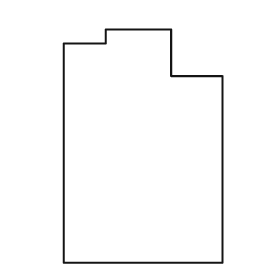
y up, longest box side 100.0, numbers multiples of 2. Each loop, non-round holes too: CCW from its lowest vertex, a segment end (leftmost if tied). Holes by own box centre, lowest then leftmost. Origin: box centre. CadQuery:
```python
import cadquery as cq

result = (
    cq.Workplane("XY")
    .moveTo(-34.0, -50.0)
    .lineTo(34.0, -50.0)
    .lineTo(34.0, 30.0)
    .lineTo(12.0, 30.0)
    .lineTo(12.0, 50.0)
    .lineTo(-16.0, 50.0)
    .lineTo(-16.0, 44.0)
    .lineTo(-34.0, 44.0)
    .close()
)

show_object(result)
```